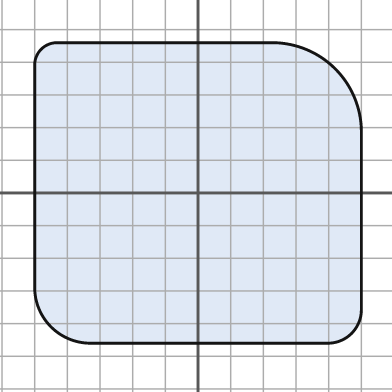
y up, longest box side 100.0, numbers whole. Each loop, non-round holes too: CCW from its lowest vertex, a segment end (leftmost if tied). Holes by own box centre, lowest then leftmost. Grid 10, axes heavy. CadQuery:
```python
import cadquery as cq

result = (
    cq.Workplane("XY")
    .moveTo(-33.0, -46.0)
    .lineTo(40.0, -46.0)
    .threePointArc((47.0, -43.0), (50.0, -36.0))
    .lineTo(50.0, 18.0)
    .threePointArc((42.0, 38.0), (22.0, 46.0))
    .lineTo(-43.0, 46.0)
    .threePointArc((-48.0, 44.0), (-50.0, 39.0))
    .lineTo(-50.0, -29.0)
    .threePointArc((-45.0, -41.0), (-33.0, -46.0))
    .close()
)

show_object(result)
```